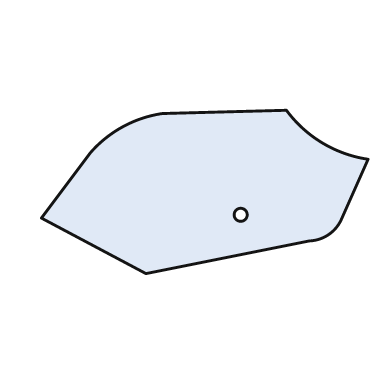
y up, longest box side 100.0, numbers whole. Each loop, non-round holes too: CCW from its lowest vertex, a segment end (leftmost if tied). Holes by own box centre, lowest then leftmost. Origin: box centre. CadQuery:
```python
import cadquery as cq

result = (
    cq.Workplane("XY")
    .moveTo(-18.0, -25.0)
    .lineTo(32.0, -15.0)
    .threePointArc((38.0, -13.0), (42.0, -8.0))
    .lineTo(50.0, 10.0)
    .threePointArc((36.0, 15.0), (25.0, 25.0))
    .lineTo(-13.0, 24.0)
    .threePointArc((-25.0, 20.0), (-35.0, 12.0))
    .lineTo(-50.0, -8.0)
    .close()
    .moveTo(11.0, -7.0)
    .circle(2.0)
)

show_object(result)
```